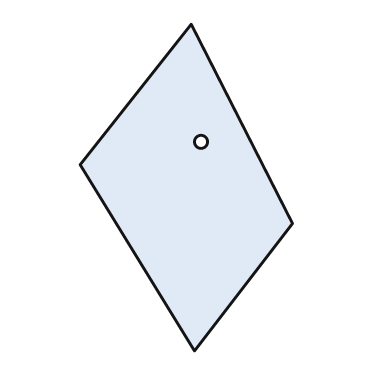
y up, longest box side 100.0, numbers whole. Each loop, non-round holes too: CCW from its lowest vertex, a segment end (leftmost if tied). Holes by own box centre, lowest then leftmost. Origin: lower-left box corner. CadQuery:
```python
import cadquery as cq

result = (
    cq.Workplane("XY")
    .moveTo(35.0, 0.0)
    .lineTo(65.0, 39.0)
    .lineTo(34.0, 100.0)
    .lineTo(0.0, 57.0)
    .close()
    .moveTo(37.0, 64.0)
    .circle(2.0)
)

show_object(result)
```